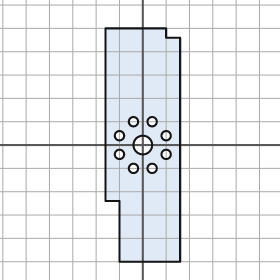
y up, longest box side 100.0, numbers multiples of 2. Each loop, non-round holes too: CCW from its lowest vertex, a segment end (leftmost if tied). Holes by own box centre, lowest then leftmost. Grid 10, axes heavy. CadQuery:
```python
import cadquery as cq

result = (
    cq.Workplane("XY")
    .moveTo(-10.0, -50.0)
    .lineTo(16.0, -50.0)
    .lineTo(16.0, 46.0)
    .lineTo(10.0, 46.0)
    .lineTo(10.0, 50.0)
    .lineTo(-16.0, 50.0)
    .lineTo(-16.0, -24.0)
    .lineTo(-10.0, -24.0)
    .close()
    .moveTo(-4.0, -10.0)
    .circle(2.0)
    .moveTo(4.0, -10.0)
    .circle(2.0)
    .moveTo(-10.0, -4.0)
    .circle(2.0)
    .moveTo(10.0, -4.0)
    .circle(2.0)
    .moveTo(0.0, 0.0)
    .circle(4.0)
    .moveTo(-10.0, 4.0)
    .circle(2.0)
    .moveTo(10.0, 4.0)
    .circle(2.0)
    .moveTo(-4.0, 10.0)
    .circle(2.0)
    .moveTo(4.0, 10.0)
    .circle(2.0)
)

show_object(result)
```